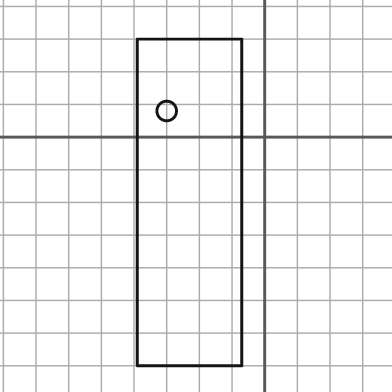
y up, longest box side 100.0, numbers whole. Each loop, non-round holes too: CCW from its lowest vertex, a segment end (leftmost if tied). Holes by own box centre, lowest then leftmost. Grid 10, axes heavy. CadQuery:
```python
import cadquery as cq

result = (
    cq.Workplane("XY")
    .moveTo(-39.0, -70.0)
    .lineTo(-7.0, -70.0)
    .lineTo(-7.0, 30.0)
    .lineTo(-39.0, 30.0)
    .close()
    .moveTo(-30.0, 8.0)
    .circle(3.0)
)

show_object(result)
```